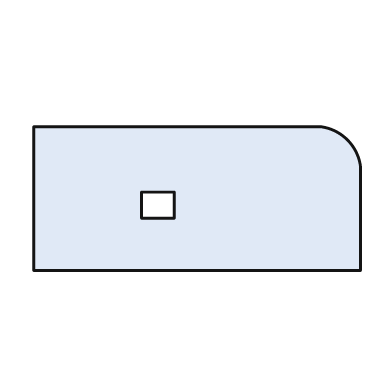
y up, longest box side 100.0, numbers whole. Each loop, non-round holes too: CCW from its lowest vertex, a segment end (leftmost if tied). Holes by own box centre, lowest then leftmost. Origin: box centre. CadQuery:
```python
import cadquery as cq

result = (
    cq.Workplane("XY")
    .moveTo(-50.0, -22.0)
    .lineTo(50.0, -22.0)
    .lineTo(50.0, 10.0)
    .threePointArc((46.0, 18.0), (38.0, 22.0))
    .lineTo(-50.0, 22.0)
    .close()
    .moveTo(-17.0, -6.0)
    .lineTo(-7.0, -6.0)
    .lineTo(-7.0, 2.0)
    .lineTo(-17.0, 2.0)
    .close()
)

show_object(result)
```